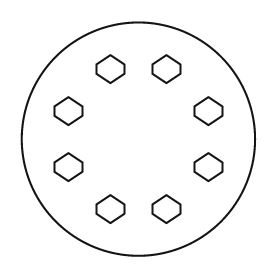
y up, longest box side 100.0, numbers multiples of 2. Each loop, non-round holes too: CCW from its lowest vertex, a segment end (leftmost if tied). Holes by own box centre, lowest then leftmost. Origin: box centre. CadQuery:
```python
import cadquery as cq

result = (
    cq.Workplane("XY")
    .moveTo(0.0, 0.0)
    .circle(50.0)
    .moveTo(-12.0, -36.0)
    .lineTo(-6.0, -32.0)
    .lineTo(-6.0, -28.0)
    .lineTo(-12.0, -24.0)
    .lineTo(-18.0, -28.0)
    .lineTo(-18.0, -32.0)
    .close()
    .moveTo(12.0, -36.0)
    .lineTo(18.0, -32.0)
    .lineTo(18.0, -28.0)
    .lineTo(12.0, -24.0)
    .lineTo(6.0, -28.0)
    .lineTo(6.0, -32.0)
    .close()
    .moveTo(-30.0, -18.0)
    .lineTo(-24.0, -14.0)
    .lineTo(-24.0, -10.0)
    .lineTo(-30.0, -6.0)
    .lineTo(-36.0, -10.0)
    .lineTo(-36.0, -14.0)
    .close()
    .moveTo(30.0, -18.0)
    .lineTo(36.0, -14.0)
    .lineTo(36.0, -10.0)
    .lineTo(30.0, -6.0)
    .lineTo(24.0, -10.0)
    .lineTo(24.0, -14.0)
    .close()
    .moveTo(-30.0, 6.0)
    .lineTo(-24.0, 10.0)
    .lineTo(-24.0, 14.0)
    .lineTo(-30.0, 18.0)
    .lineTo(-36.0, 14.0)
    .lineTo(-36.0, 10.0)
    .close()
    .moveTo(30.0, 6.0)
    .lineTo(36.0, 10.0)
    .lineTo(36.0, 14.0)
    .lineTo(30.0, 18.0)
    .lineTo(24.0, 14.0)
    .lineTo(24.0, 10.0)
    .close()
    .moveTo(-12.0, 24.0)
    .lineTo(-6.0, 28.0)
    .lineTo(-6.0, 32.0)
    .lineTo(-12.0, 36.0)
    .lineTo(-18.0, 32.0)
    .lineTo(-18.0, 28.0)
    .close()
    .moveTo(12.0, 24.0)
    .lineTo(18.0, 28.0)
    .lineTo(18.0, 32.0)
    .lineTo(12.0, 36.0)
    .lineTo(6.0, 32.0)
    .lineTo(6.0, 28.0)
    .close()
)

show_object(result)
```